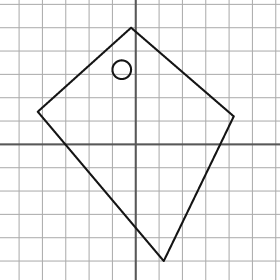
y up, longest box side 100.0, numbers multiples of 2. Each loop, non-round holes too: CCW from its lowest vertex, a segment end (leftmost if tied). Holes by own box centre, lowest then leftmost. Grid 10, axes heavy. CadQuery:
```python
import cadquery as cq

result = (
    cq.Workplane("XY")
    .moveTo(12.0, -50.0)
    .lineTo(42.0, 12.0)
    .lineTo(-2.0, 50.0)
    .lineTo(-42.0, 14.0)
    .close()
    .moveTo(-6.0, 32.0)
    .circle(4.0)
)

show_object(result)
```